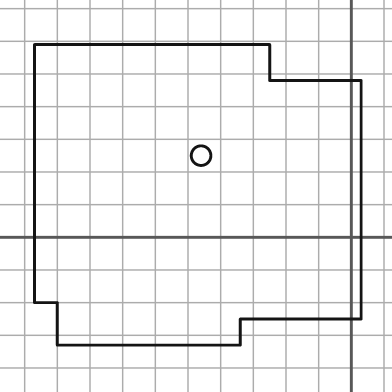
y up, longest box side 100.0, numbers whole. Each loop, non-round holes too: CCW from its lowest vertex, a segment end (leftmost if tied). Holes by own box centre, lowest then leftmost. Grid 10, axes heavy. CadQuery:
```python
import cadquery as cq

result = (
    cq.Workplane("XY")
    .moveTo(-90.0, -33.0)
    .lineTo(-34.0, -33.0)
    .lineTo(-34.0, -25.0)
    .lineTo(3.0, -25.0)
    .lineTo(3.0, 48.0)
    .lineTo(-25.0, 48.0)
    .lineTo(-25.0, 59.0)
    .lineTo(-97.0, 59.0)
    .lineTo(-97.0, -20.0)
    .lineTo(-90.0, -20.0)
    .close()
    .moveTo(-46.0, 25.0)
    .circle(3.0)
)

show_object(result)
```